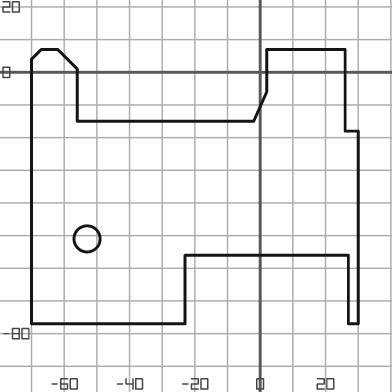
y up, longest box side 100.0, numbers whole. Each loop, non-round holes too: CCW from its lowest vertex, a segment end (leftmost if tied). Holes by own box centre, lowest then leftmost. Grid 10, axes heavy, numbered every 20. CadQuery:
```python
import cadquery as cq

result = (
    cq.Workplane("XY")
    .moveTo(-70.0, -77.0)
    .lineTo(-23.0, -77.0)
    .lineTo(-23.0, -56.0)
    .lineTo(27.0, -56.0)
    .lineTo(27.0, -77.0)
    .lineTo(30.0, -77.0)
    .lineTo(30.0, -18.0)
    .lineTo(26.0, -18.0)
    .lineTo(26.0, 7.0)
    .lineTo(2.0, 7.0)
    .lineTo(2.0, -6.0)
    .lineTo(-2.0, -15.0)
    .lineTo(-56.0, -15.0)
    .lineTo(-56.0, 1.0)
    .lineTo(-62.0, 7.0)
    .lineTo(-67.0, 7.0)
    .lineTo(-70.0, 4.0)
    .close()
    .moveTo(-53.0, -51.0)
    .circle(4.0)
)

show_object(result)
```